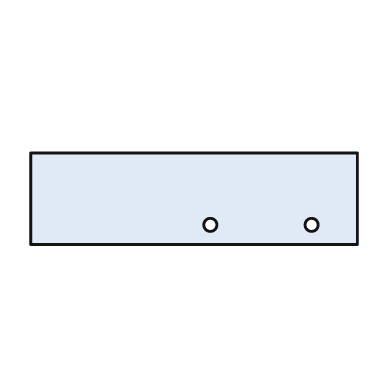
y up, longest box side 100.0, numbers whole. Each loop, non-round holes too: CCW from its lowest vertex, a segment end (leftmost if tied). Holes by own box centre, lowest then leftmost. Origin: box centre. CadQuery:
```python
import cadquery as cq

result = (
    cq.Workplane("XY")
    .moveTo(-50.0, -14.0)
    .lineTo(50.0, -14.0)
    .lineTo(50.0, 14.0)
    .lineTo(-50.0, 14.0)
    .close()
    .moveTo(5.0, -8.0)
    .circle(2.0)
    .moveTo(36.0, -8.0)
    .circle(2.0)
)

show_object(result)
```